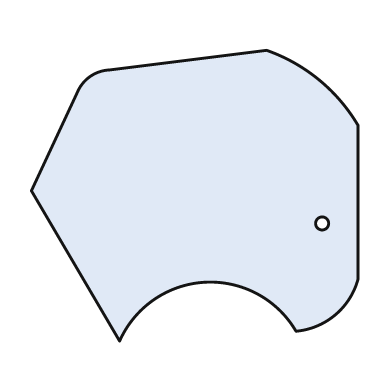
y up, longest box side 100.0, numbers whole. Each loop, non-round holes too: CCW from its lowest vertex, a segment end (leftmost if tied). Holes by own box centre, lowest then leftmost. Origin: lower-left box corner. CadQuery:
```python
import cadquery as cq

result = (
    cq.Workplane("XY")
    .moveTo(27.0, 0.0)
    .threePointArc((53.0, 18.0), (81.0, 3.0))
    .threePointArc((93.0, 8.0), (100.0, 19.0))
    .lineTo(100.0, 66.0)
    .threePointArc((88.0, 80.0), (72.0, 89.0))
    .lineTo(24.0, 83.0)
    .threePointArc((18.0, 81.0), (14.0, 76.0))
    .lineTo(0.0, 46.0)
    .close()
    .moveTo(89.0, 36.0)
    .circle(2.0)
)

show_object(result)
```